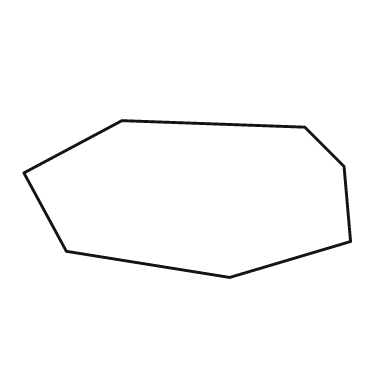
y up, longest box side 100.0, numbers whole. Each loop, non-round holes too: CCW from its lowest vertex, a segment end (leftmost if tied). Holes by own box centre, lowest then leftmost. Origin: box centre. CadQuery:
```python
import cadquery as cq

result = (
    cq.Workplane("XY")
    .moveTo(13.0, -24.0)
    .lineTo(50.0, -13.0)
    .lineTo(48.0, 10.0)
    .lineTo(36.0, 22.0)
    .lineTo(-20.0, 24.0)
    .lineTo(-50.0, 8.0)
    .lineTo(-37.0, -16.0)
    .close()
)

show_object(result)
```